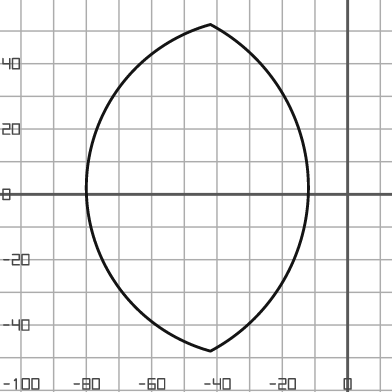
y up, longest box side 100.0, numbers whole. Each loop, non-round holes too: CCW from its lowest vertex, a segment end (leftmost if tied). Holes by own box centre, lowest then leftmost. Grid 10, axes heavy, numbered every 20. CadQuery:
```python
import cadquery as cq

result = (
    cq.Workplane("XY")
    .moveTo(-42.0, -48.0)
    .threePointArc((-12.0, 2.0), (-42.0, 52.0))
    .threePointArc((-80.0, 2.0), (-42.0, -48.0))
    .close()
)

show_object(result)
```